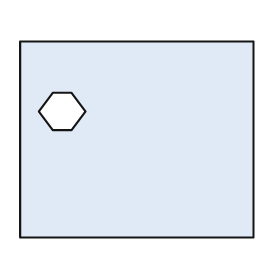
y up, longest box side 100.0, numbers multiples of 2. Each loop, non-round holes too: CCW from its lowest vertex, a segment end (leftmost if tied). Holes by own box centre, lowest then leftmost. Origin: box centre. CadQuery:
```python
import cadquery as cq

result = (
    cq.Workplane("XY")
    .moveTo(-50.0, -42.0)
    .lineTo(50.0, -42.0)
    .lineTo(50.0, 42.0)
    .lineTo(-50.0, 42.0)
    .close()
    .moveTo(-36.0, 4.0)
    .lineTo(-28.0, 4.0)
    .lineTo(-22.0, 12.0)
    .lineTo(-28.0, 20.0)
    .lineTo(-36.0, 20.0)
    .lineTo(-42.0, 12.0)
    .close()
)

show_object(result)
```